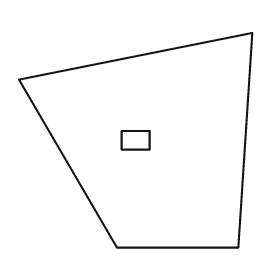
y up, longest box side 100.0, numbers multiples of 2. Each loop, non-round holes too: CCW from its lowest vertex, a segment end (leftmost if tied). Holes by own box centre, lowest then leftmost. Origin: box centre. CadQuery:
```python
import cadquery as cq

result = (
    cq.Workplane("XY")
    .moveTo(-8.0, -46.0)
    .lineTo(44.0, -46.0)
    .lineTo(50.0, 46.0)
    .lineTo(-50.0, 26.0)
    .close()
    .moveTo(-6.0, -4.0)
    .lineTo(6.0, -4.0)
    .lineTo(6.0, 4.0)
    .lineTo(-6.0, 4.0)
    .close()
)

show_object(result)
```